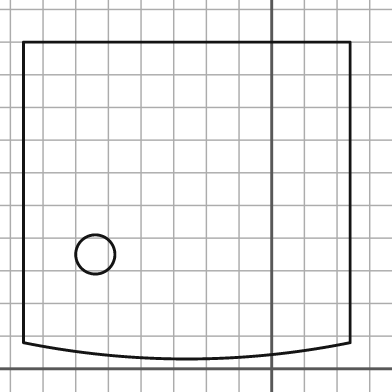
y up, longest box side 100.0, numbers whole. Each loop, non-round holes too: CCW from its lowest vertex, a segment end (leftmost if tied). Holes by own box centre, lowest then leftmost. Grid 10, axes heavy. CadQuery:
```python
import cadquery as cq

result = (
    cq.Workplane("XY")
    .moveTo(-76.0, 8.0)
    .threePointArc((-26.0, 3.0), (24.0, 8.0))
    .lineTo(24.0, 100.0)
    .lineTo(-76.0, 100.0)
    .close()
    .moveTo(-54.0, 35.0)
    .circle(6.0)
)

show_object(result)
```